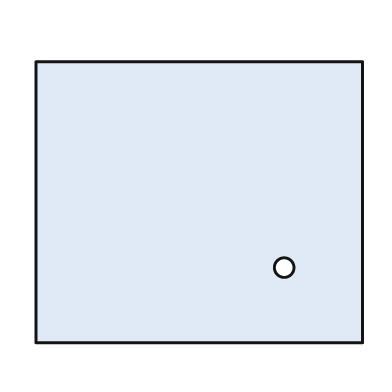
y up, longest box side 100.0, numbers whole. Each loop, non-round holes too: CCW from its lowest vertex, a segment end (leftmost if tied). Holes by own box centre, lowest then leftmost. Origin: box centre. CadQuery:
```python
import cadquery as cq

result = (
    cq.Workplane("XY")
    .moveTo(-50.0, -43.0)
    .lineTo(50.0, -43.0)
    .lineTo(50.0, 43.0)
    .lineTo(-50.0, 43.0)
    .close()
    .moveTo(26.0, -20.0)
    .circle(3.0)
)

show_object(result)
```